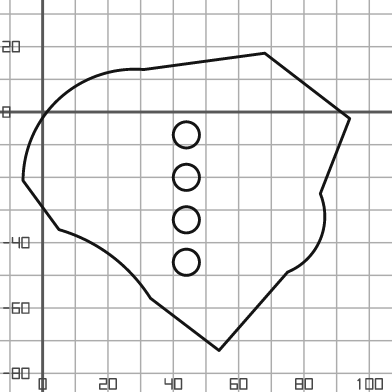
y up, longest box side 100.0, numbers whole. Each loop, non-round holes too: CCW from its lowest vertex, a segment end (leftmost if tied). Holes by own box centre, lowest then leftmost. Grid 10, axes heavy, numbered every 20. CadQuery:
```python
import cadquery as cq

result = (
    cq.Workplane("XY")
    .moveTo(54.0, -73.0)
    .lineTo(75.0, -49.0)
    .threePointArc((85.0, -39.0), (85.0, -25.0))
    .lineTo(94.0, -2.0)
    .lineTo(68.0, 18.0)
    .lineTo(31.0, 13.0)
    .threePointArc((5.0, 4.0), (-6.0, -21.0))
    .lineTo(5.0, -36.0)
    .threePointArc((21.0, -44.0), (33.0, -57.0))
    .close()
    .moveTo(44.0, -46.0)
    .circle(4.0)
    .moveTo(44.0, -33.0)
    .circle(4.0)
    .moveTo(44.0, -20.0)
    .circle(4.0)
    .moveTo(44.0, -7.0)
    .circle(4.0)
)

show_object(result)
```